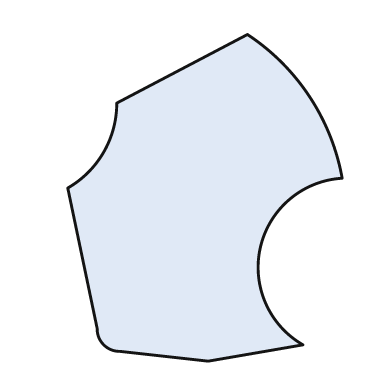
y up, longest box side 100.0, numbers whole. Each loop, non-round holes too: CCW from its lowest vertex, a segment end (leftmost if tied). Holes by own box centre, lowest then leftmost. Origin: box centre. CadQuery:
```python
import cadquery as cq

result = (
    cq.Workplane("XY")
    .moveTo(1.0, -50.0)
    .lineTo(30.0, -45.0)
    .threePointArc((17.0, -15.0), (42.0, 6.0))
    .threePointArc((32.0, 31.0), (13.0, 50.0))
    .lineTo(-27.0, 29.0)
    .threePointArc((-31.0, 14.0), (-42.0, 3.0))
    .lineTo(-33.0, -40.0)
    .threePointArc((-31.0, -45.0), (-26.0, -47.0))
    .close()
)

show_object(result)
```